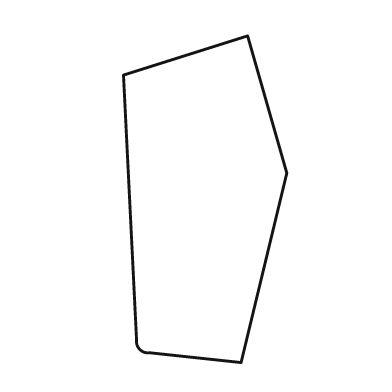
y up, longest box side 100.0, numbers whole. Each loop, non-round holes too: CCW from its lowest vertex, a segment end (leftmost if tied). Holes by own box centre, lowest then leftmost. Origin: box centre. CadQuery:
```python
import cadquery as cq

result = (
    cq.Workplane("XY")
    .moveTo(11.0, -50.0)
    .lineTo(25.0, 8.0)
    .lineTo(13.0, 50.0)
    .lineTo(-25.0, 38.0)
    .lineTo(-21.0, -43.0)
    .threePointArc((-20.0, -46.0), (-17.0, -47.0))
    .close()
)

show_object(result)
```